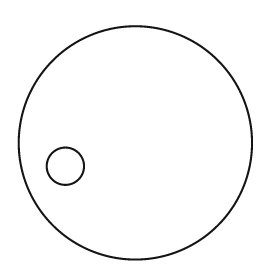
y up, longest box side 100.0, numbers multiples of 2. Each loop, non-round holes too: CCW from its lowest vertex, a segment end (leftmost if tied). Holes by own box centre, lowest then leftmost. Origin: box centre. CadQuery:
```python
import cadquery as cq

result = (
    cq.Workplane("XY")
    .moveTo(0.0, 0.0)
    .circle(50.0)
    .moveTo(-30.0, -10.0)
    .circle(8.0)
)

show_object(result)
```